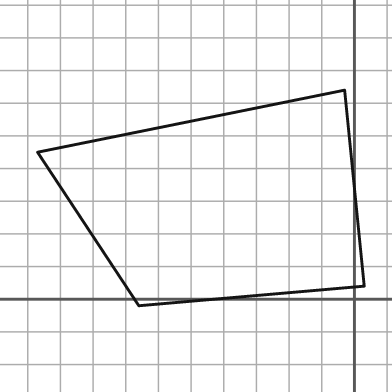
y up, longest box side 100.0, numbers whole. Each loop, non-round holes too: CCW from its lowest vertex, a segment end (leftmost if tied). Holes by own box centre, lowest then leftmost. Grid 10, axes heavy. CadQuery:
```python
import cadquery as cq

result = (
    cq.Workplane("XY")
    .moveTo(-66.0, -2.0)
    .lineTo(3.0, 4.0)
    .lineTo(-3.0, 64.0)
    .lineTo(-97.0, 45.0)
    .close()
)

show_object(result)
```